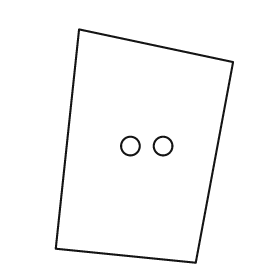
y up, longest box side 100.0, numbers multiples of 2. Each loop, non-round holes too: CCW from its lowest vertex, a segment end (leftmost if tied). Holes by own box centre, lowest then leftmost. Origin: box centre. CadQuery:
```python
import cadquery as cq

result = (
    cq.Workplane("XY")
    .moveTo(22.0, -50.0)
    .lineTo(38.0, 36.0)
    .lineTo(-28.0, 50.0)
    .lineTo(-38.0, -44.0)
    .close()
    .moveTo(-6.0, 0.0)
    .circle(4.0)
    .moveTo(8.0, 0.0)
    .circle(4.0)
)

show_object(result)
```